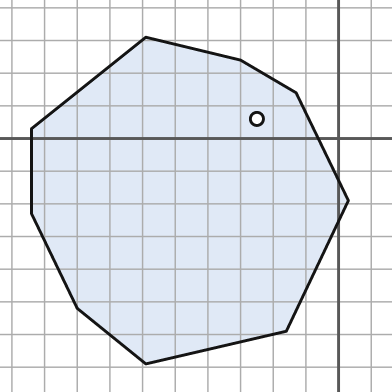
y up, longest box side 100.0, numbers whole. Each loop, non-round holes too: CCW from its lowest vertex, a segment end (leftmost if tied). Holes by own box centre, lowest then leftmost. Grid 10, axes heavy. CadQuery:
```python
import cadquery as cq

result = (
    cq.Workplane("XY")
    .moveTo(-59.0, -69.0)
    .lineTo(-16.0, -59.0)
    .lineTo(3.0, -19.0)
    .lineTo(-13.0, 14.0)
    .lineTo(-30.0, 24.0)
    .lineTo(-59.0, 31.0)
    .lineTo(-94.0, 3.0)
    .lineTo(-94.0, -23.0)
    .lineTo(-80.0, -52.0)
    .close()
    .moveTo(-25.0, 6.0)
    .circle(2.0)
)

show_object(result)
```